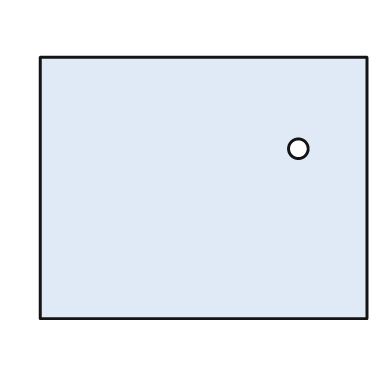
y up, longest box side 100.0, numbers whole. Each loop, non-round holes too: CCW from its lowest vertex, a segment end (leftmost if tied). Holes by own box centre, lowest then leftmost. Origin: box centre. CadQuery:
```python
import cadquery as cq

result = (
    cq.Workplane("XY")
    .moveTo(-50.0, -40.0)
    .lineTo(50.0, -40.0)
    .lineTo(50.0, 40.0)
    .lineTo(-50.0, 40.0)
    .close()
    .moveTo(29.0, 12.0)
    .circle(3.0)
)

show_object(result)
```